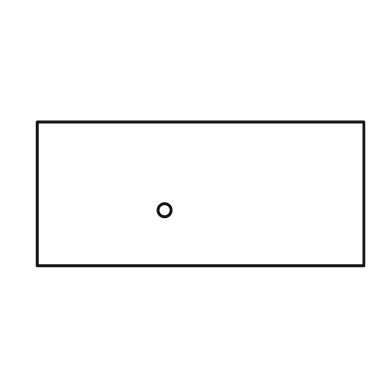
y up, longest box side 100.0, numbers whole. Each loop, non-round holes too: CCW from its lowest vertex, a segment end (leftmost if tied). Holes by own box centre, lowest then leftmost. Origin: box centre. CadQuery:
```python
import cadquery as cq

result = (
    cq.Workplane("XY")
    .moveTo(-50.0, -22.0)
    .lineTo(50.0, -22.0)
    .lineTo(50.0, 22.0)
    .lineTo(-50.0, 22.0)
    .close()
    .moveTo(-11.0, -5.0)
    .circle(2.0)
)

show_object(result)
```